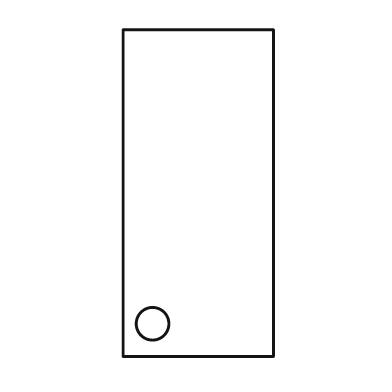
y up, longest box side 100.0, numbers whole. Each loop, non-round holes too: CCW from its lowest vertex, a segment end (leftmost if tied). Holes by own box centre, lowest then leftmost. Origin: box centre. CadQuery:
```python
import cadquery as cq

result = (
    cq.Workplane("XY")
    .moveTo(-23.0, -50.0)
    .lineTo(23.0, -50.0)
    .lineTo(23.0, 50.0)
    .lineTo(-23.0, 50.0)
    .close()
    .moveTo(-14.0, -40.0)
    .circle(5.0)
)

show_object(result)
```